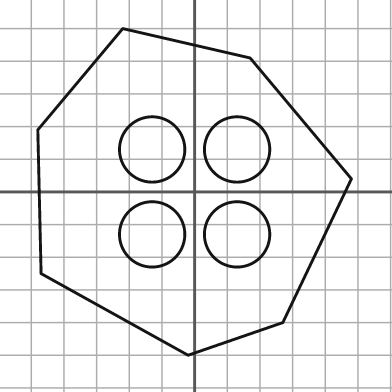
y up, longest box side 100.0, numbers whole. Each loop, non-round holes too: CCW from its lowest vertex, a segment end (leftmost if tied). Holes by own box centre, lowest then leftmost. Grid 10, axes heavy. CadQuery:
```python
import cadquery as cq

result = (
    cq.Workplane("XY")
    .moveTo(-2.0, -50.0)
    .lineTo(27.0, -40.0)
    .lineTo(48.0, 4.0)
    .lineTo(17.0, 41.0)
    .lineTo(-22.0, 50.0)
    .lineTo(-48.0, 19.0)
    .lineTo(-47.0, -25.0)
    .close()
    .moveTo(-13.0, -13.0)
    .circle(10.0)
    .moveTo(13.0, -13.0)
    .circle(10.0)
    .moveTo(-13.0, 13.0)
    .circle(10.0)
    .moveTo(13.0, 13.0)
    .circle(10.0)
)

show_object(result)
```